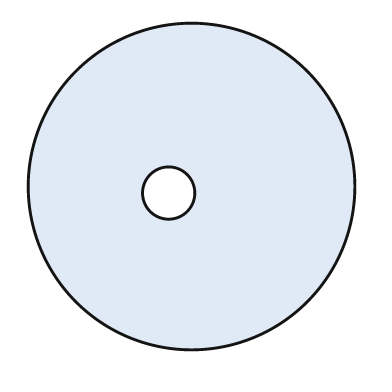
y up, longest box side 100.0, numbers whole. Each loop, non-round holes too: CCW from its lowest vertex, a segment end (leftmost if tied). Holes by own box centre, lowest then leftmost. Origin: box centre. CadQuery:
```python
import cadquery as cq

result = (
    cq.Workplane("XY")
    .moveTo(0.0, 0.0)
    .circle(50.0)
    .moveTo(-7.0, -2.0)
    .circle(8.0)
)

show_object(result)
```